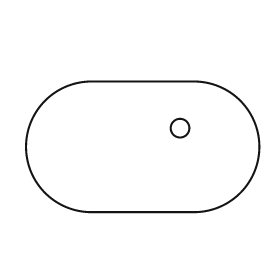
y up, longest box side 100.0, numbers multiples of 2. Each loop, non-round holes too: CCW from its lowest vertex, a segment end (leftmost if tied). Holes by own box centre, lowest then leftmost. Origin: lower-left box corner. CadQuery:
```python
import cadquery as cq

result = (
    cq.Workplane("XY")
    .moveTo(28.0, 0.0)
    .lineTo(72.0, 0.0)
    .threePointArc((100.0, 28.0), (72.0, 56.0))
    .lineTo(28.0, 56.0)
    .threePointArc((0.0, 28.0), (28.0, 0.0))
    .close()
    .moveTo(66.0, 36.0)
    .circle(4.0)
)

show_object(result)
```